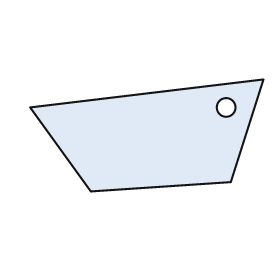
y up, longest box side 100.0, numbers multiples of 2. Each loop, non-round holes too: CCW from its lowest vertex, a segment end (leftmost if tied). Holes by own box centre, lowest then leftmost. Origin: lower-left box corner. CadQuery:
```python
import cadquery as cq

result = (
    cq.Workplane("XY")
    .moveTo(26.0, 0.0)
    .lineTo(86.0, 4.0)
    .lineTo(100.0, 48.0)
    .lineTo(0.0, 36.0)
    .close()
    .moveTo(84.0, 36.0)
    .circle(4.0)
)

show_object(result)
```